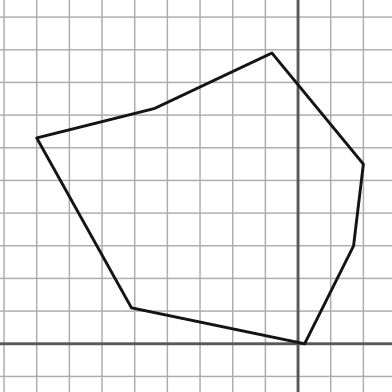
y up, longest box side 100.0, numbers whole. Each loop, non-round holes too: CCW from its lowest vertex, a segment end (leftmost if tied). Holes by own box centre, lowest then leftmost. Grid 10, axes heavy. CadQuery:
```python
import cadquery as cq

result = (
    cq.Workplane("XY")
    .moveTo(2.0, 0.0)
    .lineTo(17.0, 30.0)
    .lineTo(20.0, 55.0)
    .lineTo(-8.0, 89.0)
    .lineTo(-44.0, 72.0)
    .lineTo(-80.0, 63.0)
    .lineTo(-51.0, 11.0)
    .close()
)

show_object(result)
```